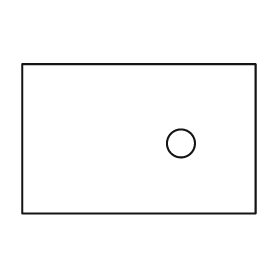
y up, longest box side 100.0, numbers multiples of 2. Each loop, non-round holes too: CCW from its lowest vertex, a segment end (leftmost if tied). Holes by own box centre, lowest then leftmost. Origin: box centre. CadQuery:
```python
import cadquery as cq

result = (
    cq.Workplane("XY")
    .moveTo(-50.0, -32.0)
    .lineTo(50.0, -32.0)
    .lineTo(50.0, 32.0)
    .lineTo(-50.0, 32.0)
    .close()
    .moveTo(18.0, -2.0)
    .circle(6.0)
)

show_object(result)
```